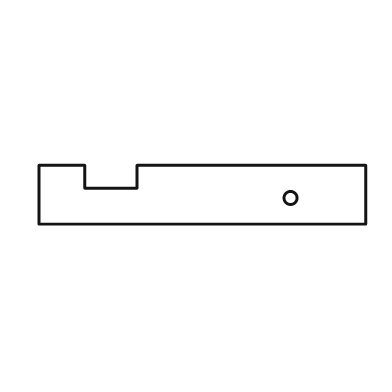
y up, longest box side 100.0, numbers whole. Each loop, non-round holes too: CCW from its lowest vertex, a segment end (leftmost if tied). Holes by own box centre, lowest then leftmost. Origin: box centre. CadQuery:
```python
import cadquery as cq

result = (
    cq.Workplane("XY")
    .moveTo(-50.0, -9.0)
    .lineTo(50.0, -9.0)
    .lineTo(50.0, 9.0)
    .lineTo(-20.0, 9.0)
    .lineTo(-20.0, 2.0)
    .lineTo(-36.0, 2.0)
    .lineTo(-36.0, 9.0)
    .lineTo(-50.0, 9.0)
    .close()
    .moveTo(27.0, -1.0)
    .circle(2.0)
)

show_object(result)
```